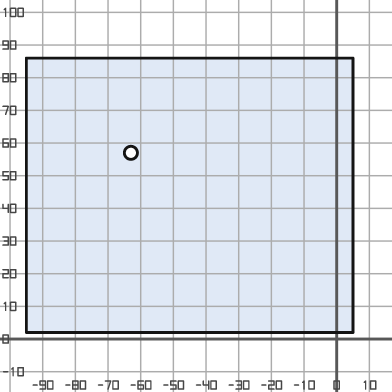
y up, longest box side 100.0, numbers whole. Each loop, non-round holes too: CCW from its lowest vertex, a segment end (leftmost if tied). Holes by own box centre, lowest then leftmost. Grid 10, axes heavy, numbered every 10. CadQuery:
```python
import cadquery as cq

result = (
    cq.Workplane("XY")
    .moveTo(-95.0, 2.0)
    .lineTo(5.0, 2.0)
    .lineTo(5.0, 86.0)
    .lineTo(-95.0, 86.0)
    .close()
    .moveTo(-63.0, 57.0)
    .circle(2.0)
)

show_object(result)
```